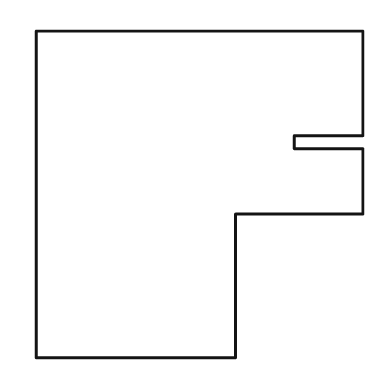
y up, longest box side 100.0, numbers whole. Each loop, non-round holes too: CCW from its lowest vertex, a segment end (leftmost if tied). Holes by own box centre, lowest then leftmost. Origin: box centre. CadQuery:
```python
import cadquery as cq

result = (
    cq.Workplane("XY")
    .moveTo(-50.0, -50.0)
    .lineTo(11.0, -50.0)
    .lineTo(11.0, -6.0)
    .lineTo(50.0, -6.0)
    .lineTo(50.0, 14.0)
    .lineTo(29.0, 14.0)
    .lineTo(29.0, 18.0)
    .lineTo(50.0, 18.0)
    .lineTo(50.0, 50.0)
    .lineTo(-50.0, 50.0)
    .close()
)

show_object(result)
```